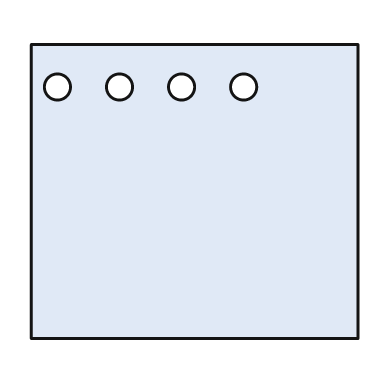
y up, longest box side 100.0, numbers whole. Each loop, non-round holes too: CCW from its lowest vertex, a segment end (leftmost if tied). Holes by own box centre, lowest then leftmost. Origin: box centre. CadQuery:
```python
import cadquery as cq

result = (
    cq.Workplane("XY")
    .moveTo(-50.0, -45.0)
    .lineTo(50.0, -45.0)
    .lineTo(50.0, 45.0)
    .lineTo(-50.0, 45.0)
    .close()
    .moveTo(-42.0, 32.0)
    .circle(4.0)
    .moveTo(-23.0, 32.0)
    .circle(4.0)
    .moveTo(-4.0, 32.0)
    .circle(4.0)
    .moveTo(15.0, 32.0)
    .circle(4.0)
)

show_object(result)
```